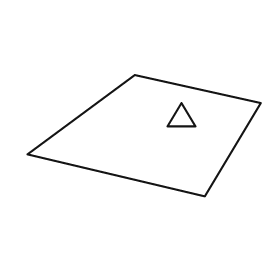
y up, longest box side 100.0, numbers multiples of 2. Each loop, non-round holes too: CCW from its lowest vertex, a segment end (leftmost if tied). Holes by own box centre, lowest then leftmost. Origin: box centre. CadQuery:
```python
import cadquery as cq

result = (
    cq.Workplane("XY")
    .moveTo(26.0, -26.0)
    .lineTo(50.0, 14.0)
    .lineTo(-4.0, 26.0)
    .lineTo(-50.0, -8.0)
    .close()
    .moveTo(10.0, 4.0)
    .lineTo(22.0, 4.0)
    .lineTo(16.0, 14.0)
    .close()
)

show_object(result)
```